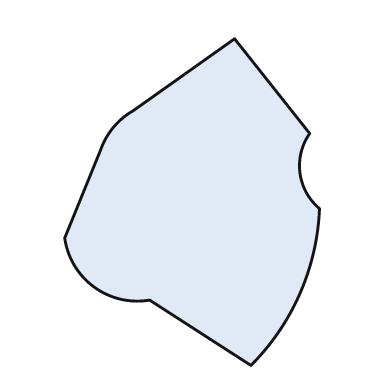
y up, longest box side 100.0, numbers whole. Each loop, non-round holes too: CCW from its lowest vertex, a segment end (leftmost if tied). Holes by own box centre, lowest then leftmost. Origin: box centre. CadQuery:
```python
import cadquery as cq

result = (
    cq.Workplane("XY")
    .moveTo(18.0, -50.0)
    .threePointArc((33.0, -28.0), (39.0, -2.0))
    .threePointArc((33.0, 9.0), (36.0, 21.0))
    .lineTo(13.0, 50.0)
    .lineTo(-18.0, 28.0)
    .threePointArc((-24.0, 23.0), (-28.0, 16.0))
    .lineTo(-39.0, -11.0)
    .threePointArc((-30.0, -26.0), (-13.0, -30.0))
    .close()
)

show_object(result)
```